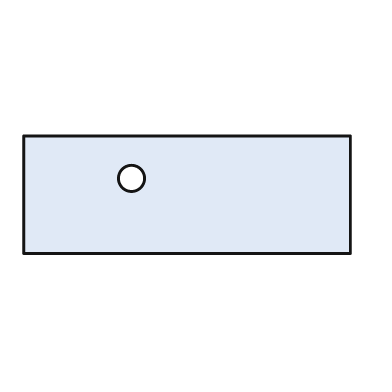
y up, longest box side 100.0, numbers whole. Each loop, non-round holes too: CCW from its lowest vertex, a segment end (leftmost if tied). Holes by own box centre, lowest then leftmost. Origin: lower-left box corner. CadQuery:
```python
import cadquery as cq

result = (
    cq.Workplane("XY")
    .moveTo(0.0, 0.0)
    .lineTo(100.0, 0.0)
    .lineTo(100.0, 36.0)
    .lineTo(0.0, 36.0)
    .close()
    .moveTo(33.0, 23.0)
    .circle(4.0)
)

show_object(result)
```